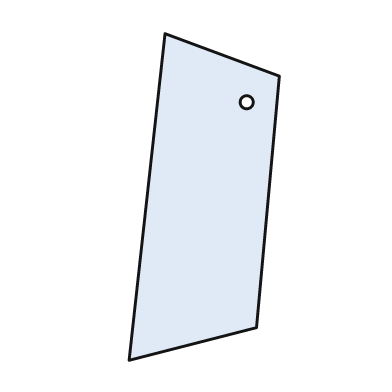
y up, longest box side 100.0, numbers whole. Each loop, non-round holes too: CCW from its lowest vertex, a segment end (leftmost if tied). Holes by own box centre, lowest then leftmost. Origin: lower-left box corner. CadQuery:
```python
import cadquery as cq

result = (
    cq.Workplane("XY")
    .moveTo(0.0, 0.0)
    .lineTo(39.0, 10.0)
    .lineTo(46.0, 87.0)
    .lineTo(11.0, 100.0)
    .close()
    .moveTo(36.0, 79.0)
    .circle(2.0)
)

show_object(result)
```